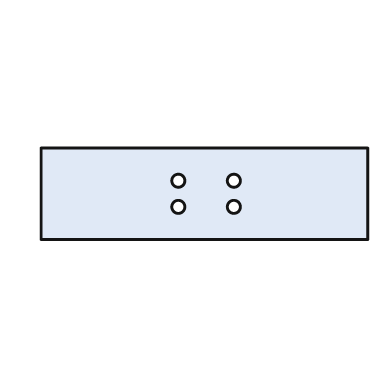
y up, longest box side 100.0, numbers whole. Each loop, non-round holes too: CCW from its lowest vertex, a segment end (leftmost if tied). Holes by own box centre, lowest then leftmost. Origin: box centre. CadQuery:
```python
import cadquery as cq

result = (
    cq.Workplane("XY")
    .moveTo(-50.0, -14.0)
    .lineTo(50.0, -14.0)
    .lineTo(50.0, 14.0)
    .lineTo(-50.0, 14.0)
    .close()
    .moveTo(-8.0, -4.0)
    .circle(2.0)
    .moveTo(9.0, -4.0)
    .circle(2.0)
    .moveTo(-8.0, 4.0)
    .circle(2.0)
    .moveTo(9.0, 4.0)
    .circle(2.0)
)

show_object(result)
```